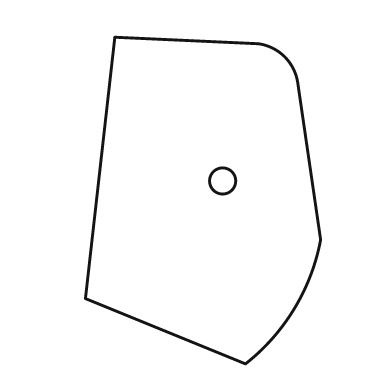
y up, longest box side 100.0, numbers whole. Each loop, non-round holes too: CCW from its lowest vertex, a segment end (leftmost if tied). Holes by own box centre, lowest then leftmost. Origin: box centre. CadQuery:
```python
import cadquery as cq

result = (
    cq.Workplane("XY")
    .moveTo(13.0, -50.0)
    .threePointArc((28.0, -33.0), (36.0, -12.0))
    .lineTo(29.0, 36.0)
    .threePointArc((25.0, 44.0), (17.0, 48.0))
    .lineTo(-27.0, 50.0)
    .lineTo(-36.0, -30.0)
    .close()
    .moveTo(6.0, 6.0)
    .circle(4.0)
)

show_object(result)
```